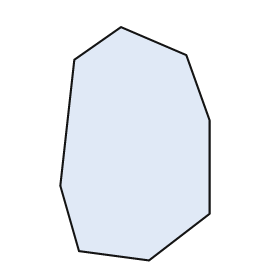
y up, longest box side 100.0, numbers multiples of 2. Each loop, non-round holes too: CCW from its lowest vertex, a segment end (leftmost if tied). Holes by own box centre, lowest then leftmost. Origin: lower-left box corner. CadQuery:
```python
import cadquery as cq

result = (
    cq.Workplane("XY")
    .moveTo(38.0, 0.0)
    .lineTo(64.0, 20.0)
    .lineTo(64.0, 60.0)
    .lineTo(54.0, 88.0)
    .lineTo(26.0, 100.0)
    .lineTo(6.0, 86.0)
    .lineTo(0.0, 32.0)
    .lineTo(8.0, 4.0)
    .close()
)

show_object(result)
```